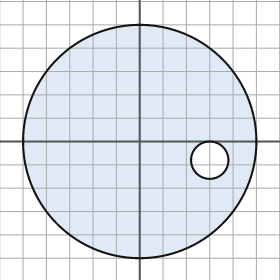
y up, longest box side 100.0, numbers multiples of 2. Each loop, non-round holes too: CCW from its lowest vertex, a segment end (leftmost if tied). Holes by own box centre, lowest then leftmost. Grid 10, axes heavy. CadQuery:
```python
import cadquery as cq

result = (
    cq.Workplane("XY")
    .moveTo(0.0, 0.0)
    .circle(50.0)
    .moveTo(30.0, -8.0)
    .circle(8.0)
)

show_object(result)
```